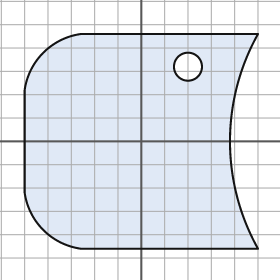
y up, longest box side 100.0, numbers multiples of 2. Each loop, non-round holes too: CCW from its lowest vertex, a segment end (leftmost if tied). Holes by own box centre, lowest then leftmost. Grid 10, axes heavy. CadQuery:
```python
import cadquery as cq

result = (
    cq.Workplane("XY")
    .moveTo(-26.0, -46.0)
    .lineTo(50.0, -46.0)
    .threePointArc((38.0, 0.0), (50.0, 46.0))
    .lineTo(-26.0, 46.0)
    .threePointArc((-42.0, 38.0), (-50.0, 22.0))
    .lineTo(-50.0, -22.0)
    .threePointArc((-42.0, -38.0), (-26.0, -46.0))
    .close()
    .moveTo(20.0, 32.0)
    .circle(6.0)
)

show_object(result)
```